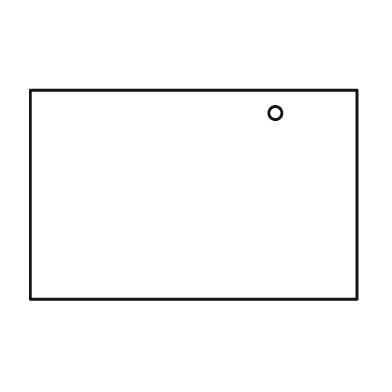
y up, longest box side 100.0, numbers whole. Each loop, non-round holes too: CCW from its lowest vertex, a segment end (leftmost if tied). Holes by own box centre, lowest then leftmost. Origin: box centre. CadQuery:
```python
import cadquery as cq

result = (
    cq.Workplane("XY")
    .moveTo(-50.0, -32.0)
    .lineTo(50.0, -32.0)
    .lineTo(50.0, 32.0)
    .lineTo(-50.0, 32.0)
    .close()
    .moveTo(25.0, 25.0)
    .circle(2.0)
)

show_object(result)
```